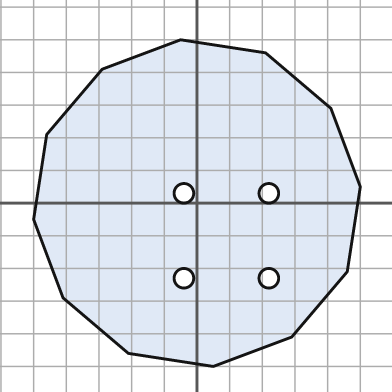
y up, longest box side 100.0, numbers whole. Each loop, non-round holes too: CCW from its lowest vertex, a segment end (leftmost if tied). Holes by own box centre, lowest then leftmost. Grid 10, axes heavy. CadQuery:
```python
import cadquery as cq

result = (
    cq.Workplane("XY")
    .moveTo(5.0, -50.0)
    .lineTo(29.0, -41.0)
    .lineTo(46.0, -21.0)
    .lineTo(50.0, 5.0)
    .lineTo(41.0, 29.0)
    .lineTo(21.0, 46.0)
    .lineTo(-5.0, 50.0)
    .lineTo(-29.0, 41.0)
    .lineTo(-46.0, 21.0)
    .lineTo(-50.0, -5.0)
    .lineTo(-41.0, -29.0)
    .lineTo(-21.0, -46.0)
    .close()
    .moveTo(-4.0, -23.0)
    .circle(3.0)
    .moveTo(22.0, -23.0)
    .circle(3.0)
    .moveTo(-4.0, 3.0)
    .circle(3.0)
    .moveTo(22.0, 3.0)
    .circle(3.0)
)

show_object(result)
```